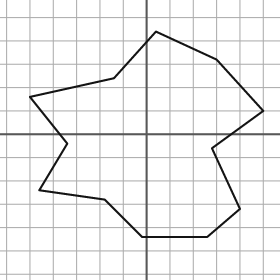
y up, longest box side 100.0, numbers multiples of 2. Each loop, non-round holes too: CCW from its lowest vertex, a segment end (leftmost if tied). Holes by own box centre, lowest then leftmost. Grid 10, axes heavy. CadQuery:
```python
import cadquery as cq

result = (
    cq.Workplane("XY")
    .moveTo(-2.0, -44.0)
    .lineTo(26.0, -44.0)
    .lineTo(40.0, -32.0)
    .lineTo(28.0, -6.0)
    .lineTo(50.0, 10.0)
    .lineTo(30.0, 32.0)
    .lineTo(4.0, 44.0)
    .lineTo(-14.0, 24.0)
    .lineTo(-50.0, 16.0)
    .lineTo(-34.0, -4.0)
    .lineTo(-46.0, -24.0)
    .lineTo(-18.0, -28.0)
    .close()
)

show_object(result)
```